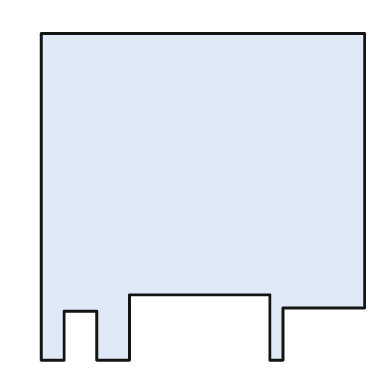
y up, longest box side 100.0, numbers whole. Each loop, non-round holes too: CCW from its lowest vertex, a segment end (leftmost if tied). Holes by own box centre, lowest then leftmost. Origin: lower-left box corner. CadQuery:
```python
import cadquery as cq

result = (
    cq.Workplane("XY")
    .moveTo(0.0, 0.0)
    .lineTo(7.0, 0.0)
    .lineTo(7.0, 15.0)
    .lineTo(17.0, 15.0)
    .lineTo(17.0, 0.0)
    .lineTo(27.0, 0.0)
    .lineTo(27.0, 20.0)
    .lineTo(70.0, 20.0)
    .lineTo(70.0, 0.0)
    .lineTo(74.0, 0.0)
    .lineTo(74.0, 16.0)
    .lineTo(99.0, 16.0)
    .lineTo(99.0, 100.0)
    .lineTo(0.0, 100.0)
    .close()
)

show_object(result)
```